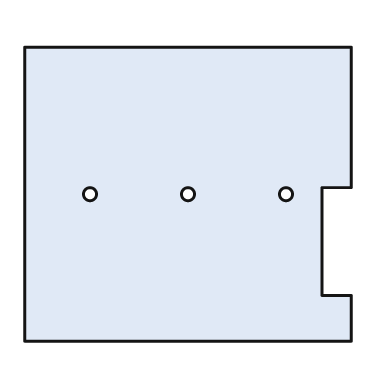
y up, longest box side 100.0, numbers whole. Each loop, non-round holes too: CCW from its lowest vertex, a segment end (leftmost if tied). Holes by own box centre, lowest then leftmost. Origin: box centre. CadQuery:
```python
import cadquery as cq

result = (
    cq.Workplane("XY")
    .moveTo(-50.0, -45.0)
    .lineTo(50.0, -45.0)
    .lineTo(50.0, -31.0)
    .lineTo(41.0, -31.0)
    .lineTo(41.0, 2.0)
    .lineTo(50.0, 2.0)
    .lineTo(50.0, 45.0)
    .lineTo(-50.0, 45.0)
    .close()
    .moveTo(-30.0, 0.0)
    .circle(2.0)
    .moveTo(0.0, 0.0)
    .circle(2.0)
    .moveTo(30.0, 0.0)
    .circle(2.0)
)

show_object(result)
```